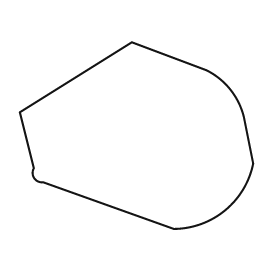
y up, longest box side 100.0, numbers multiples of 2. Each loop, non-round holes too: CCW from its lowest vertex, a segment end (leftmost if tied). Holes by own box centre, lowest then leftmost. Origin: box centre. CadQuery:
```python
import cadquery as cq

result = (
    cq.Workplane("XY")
    .moveTo(16.0, -40.0)
    .threePointArc((38.0, -32.0), (50.0, -12.0))
    .lineTo(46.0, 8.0)
    .threePointArc((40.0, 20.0), (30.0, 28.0))
    .lineTo(-2.0, 40.0)
    .lineTo(-50.0, 10.0)
    .lineTo(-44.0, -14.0)
    .threePointArc((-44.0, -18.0), (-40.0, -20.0))
    .close()
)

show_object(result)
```